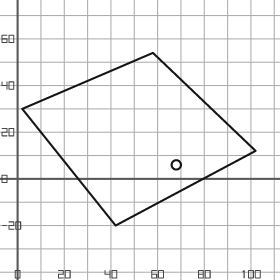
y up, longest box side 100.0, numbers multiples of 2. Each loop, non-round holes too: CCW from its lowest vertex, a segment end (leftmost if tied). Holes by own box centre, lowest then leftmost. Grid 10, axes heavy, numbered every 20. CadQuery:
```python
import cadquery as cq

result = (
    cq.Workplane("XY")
    .moveTo(42.0, -20.0)
    .lineTo(102.0, 12.0)
    .lineTo(58.0, 54.0)
    .lineTo(2.0, 30.0)
    .close()
    .moveTo(68.0, 6.0)
    .circle(2.0)
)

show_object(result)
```